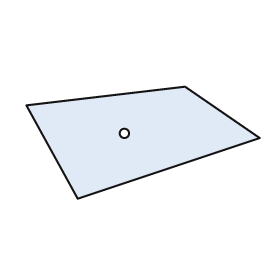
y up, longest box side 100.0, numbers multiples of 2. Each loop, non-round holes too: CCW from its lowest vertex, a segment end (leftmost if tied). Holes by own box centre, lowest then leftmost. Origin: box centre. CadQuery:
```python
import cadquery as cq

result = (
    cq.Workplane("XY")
    .moveTo(-28.0, -24.0)
    .lineTo(50.0, 2.0)
    .lineTo(18.0, 24.0)
    .lineTo(-50.0, 16.0)
    .close()
    .moveTo(-8.0, 4.0)
    .circle(2.0)
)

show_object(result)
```